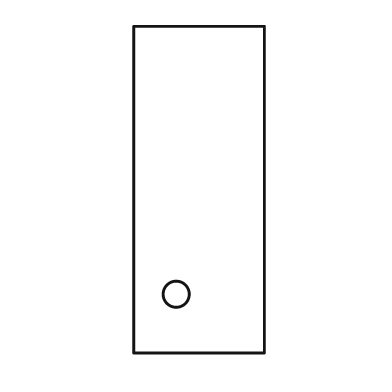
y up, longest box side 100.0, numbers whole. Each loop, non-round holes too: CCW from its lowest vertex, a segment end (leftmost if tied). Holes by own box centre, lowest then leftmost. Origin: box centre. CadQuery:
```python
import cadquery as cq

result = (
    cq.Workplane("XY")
    .moveTo(-20.0, -50.0)
    .lineTo(20.0, -50.0)
    .lineTo(20.0, 50.0)
    .lineTo(-20.0, 50.0)
    .close()
    .moveTo(-7.0, -32.0)
    .circle(4.0)
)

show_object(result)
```